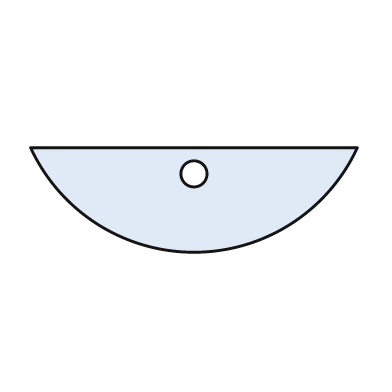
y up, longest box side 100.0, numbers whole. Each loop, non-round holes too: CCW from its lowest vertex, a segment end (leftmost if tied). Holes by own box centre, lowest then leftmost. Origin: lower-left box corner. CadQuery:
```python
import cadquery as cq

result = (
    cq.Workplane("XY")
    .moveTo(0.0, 32.0)
    .threePointArc((50.0, 0.0), (100.0, 32.0))
    .close()
    .moveTo(50.0, 24.0)
    .circle(4.0)
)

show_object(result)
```